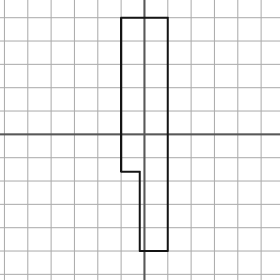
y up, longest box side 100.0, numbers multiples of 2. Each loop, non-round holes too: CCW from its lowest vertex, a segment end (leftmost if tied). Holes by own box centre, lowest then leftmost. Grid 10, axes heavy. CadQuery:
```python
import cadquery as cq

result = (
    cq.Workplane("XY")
    .moveTo(-2.0, -50.0)
    .lineTo(10.0, -50.0)
    .lineTo(10.0, 50.0)
    .lineTo(-10.0, 50.0)
    .lineTo(-10.0, -16.0)
    .lineTo(-2.0, -16.0)
    .close()
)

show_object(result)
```